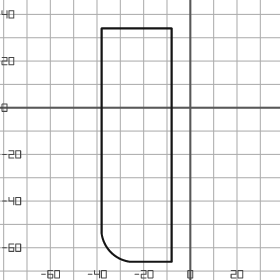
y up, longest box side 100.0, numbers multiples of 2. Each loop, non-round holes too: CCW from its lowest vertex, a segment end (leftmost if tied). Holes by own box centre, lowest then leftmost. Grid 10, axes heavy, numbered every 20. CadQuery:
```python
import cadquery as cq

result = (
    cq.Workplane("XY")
    .moveTo(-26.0, -66.0)
    .lineTo(-8.0, -66.0)
    .lineTo(-8.0, 34.0)
    .lineTo(-38.0, 34.0)
    .lineTo(-38.0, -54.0)
    .threePointArc((-34.0, -62.0), (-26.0, -66.0))
    .close()
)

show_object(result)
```